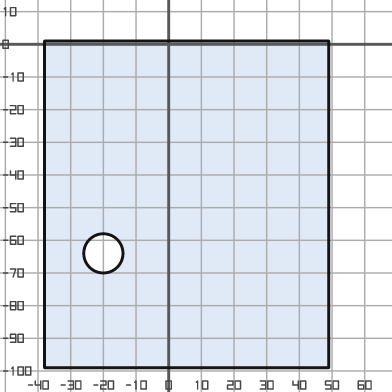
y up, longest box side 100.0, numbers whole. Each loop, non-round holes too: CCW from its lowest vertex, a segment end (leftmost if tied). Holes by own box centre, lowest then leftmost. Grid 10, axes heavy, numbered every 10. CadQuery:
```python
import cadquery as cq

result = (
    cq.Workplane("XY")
    .moveTo(-38.0, -99.0)
    .lineTo(49.0, -99.0)
    .lineTo(49.0, 1.0)
    .lineTo(-38.0, 1.0)
    .close()
    .moveTo(-20.0, -64.0)
    .circle(6.0)
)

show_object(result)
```